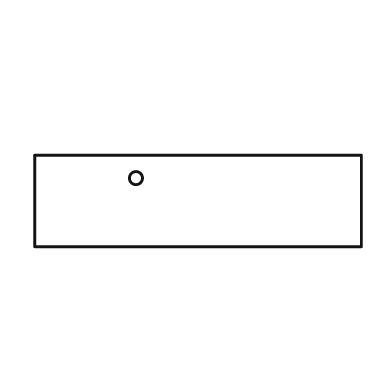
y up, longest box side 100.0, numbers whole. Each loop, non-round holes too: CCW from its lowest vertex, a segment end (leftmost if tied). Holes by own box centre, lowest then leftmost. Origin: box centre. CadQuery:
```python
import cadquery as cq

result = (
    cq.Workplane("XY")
    .moveTo(-50.0, -14.0)
    .lineTo(50.0, -14.0)
    .lineTo(50.0, 14.0)
    .lineTo(-50.0, 14.0)
    .close()
    .moveTo(-19.0, 7.0)
    .circle(2.0)
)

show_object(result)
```